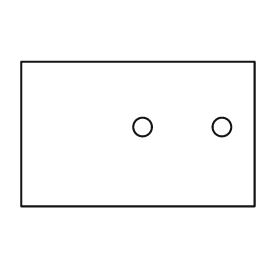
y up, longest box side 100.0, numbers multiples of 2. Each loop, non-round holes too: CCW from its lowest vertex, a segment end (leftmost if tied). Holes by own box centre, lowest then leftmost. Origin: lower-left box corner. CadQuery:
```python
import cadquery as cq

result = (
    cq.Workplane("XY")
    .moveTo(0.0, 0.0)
    .lineTo(100.0, 0.0)
    .lineTo(100.0, 62.0)
    .lineTo(0.0, 62.0)
    .close()
    .moveTo(52.0, 34.0)
    .circle(4.0)
    .moveTo(86.0, 34.0)
    .circle(4.0)
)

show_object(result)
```